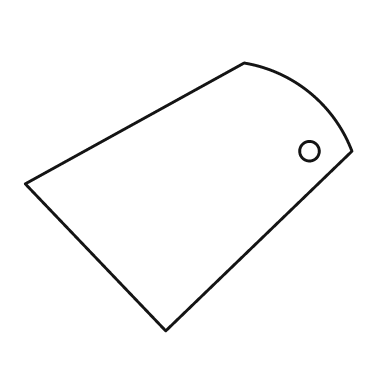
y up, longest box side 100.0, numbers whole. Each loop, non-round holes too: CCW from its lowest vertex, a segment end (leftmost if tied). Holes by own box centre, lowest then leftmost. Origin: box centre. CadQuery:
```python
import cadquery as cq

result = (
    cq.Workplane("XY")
    .moveTo(-7.0, -41.0)
    .lineTo(50.0, 14.0)
    .threePointArc((37.0, 32.0), (17.0, 41.0))
    .lineTo(-50.0, 4.0)
    .close()
    .moveTo(37.0, 14.0)
    .circle(3.0)
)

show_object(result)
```